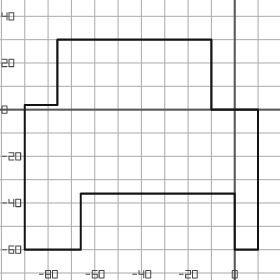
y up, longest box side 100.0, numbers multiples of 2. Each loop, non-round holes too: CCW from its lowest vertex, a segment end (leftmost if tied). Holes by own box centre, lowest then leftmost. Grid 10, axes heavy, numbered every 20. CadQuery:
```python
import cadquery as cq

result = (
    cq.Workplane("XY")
    .moveTo(-90.0, -60.0)
    .lineTo(-66.0, -60.0)
    .lineTo(-66.0, -36.0)
    .lineTo(0.0, -36.0)
    .lineTo(0.0, -60.0)
    .lineTo(10.0, -60.0)
    .lineTo(10.0, 0.0)
    .lineTo(-10.0, 0.0)
    .lineTo(-10.0, 30.0)
    .lineTo(-76.0, 30.0)
    .lineTo(-76.0, 2.0)
    .lineTo(-90.0, 2.0)
    .close()
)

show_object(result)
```